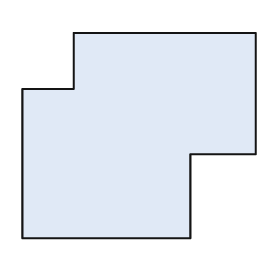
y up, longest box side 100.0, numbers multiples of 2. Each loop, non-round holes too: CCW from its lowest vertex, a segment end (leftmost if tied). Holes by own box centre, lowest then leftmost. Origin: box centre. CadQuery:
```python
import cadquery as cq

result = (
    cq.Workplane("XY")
    .moveTo(-50.0, -44.0)
    .lineTo(22.0, -44.0)
    .lineTo(22.0, -8.0)
    .lineTo(50.0, -8.0)
    .lineTo(50.0, 44.0)
    .lineTo(-28.0, 44.0)
    .lineTo(-28.0, 20.0)
    .lineTo(-50.0, 20.0)
    .close()
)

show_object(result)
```